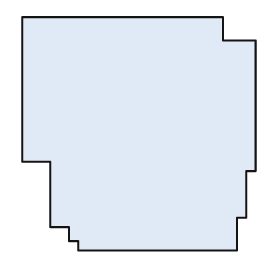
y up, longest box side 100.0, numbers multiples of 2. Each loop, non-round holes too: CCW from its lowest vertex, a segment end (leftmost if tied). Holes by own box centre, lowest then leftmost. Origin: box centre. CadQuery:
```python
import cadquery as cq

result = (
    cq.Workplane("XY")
    .moveTo(-26.0, -50.0)
    .lineTo(42.0, -50.0)
    .lineTo(42.0, -36.0)
    .lineTo(46.0, -36.0)
    .lineTo(46.0, -16.0)
    .lineTo(50.0, -16.0)
    .lineTo(50.0, 40.0)
    .lineTo(36.0, 40.0)
    .lineTo(36.0, 50.0)
    .lineTo(-50.0, 50.0)
    .lineTo(-50.0, -12.0)
    .lineTo(-38.0, -12.0)
    .lineTo(-38.0, -40.0)
    .lineTo(-30.0, -40.0)
    .lineTo(-30.0, -46.0)
    .lineTo(-26.0, -46.0)
    .close()
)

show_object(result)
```